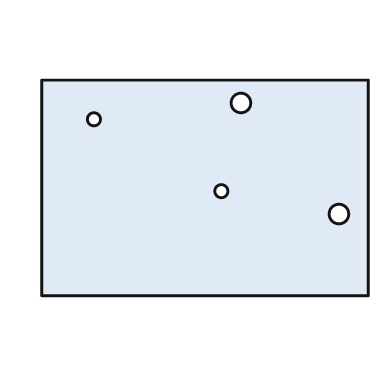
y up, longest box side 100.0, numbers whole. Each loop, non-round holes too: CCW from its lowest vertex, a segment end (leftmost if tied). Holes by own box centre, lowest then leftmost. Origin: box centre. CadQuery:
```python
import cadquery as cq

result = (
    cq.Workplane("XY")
    .moveTo(-50.0, -33.0)
    .lineTo(50.0, -33.0)
    .lineTo(50.0, 33.0)
    .lineTo(-50.0, 33.0)
    .close()
    .moveTo(41.0, -8.0)
    .circle(3.0)
    .moveTo(5.0, -1.0)
    .circle(2.0)
    .moveTo(-34.0, 21.0)
    .circle(2.0)
    .moveTo(11.0, 26.0)
    .circle(3.0)
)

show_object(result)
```